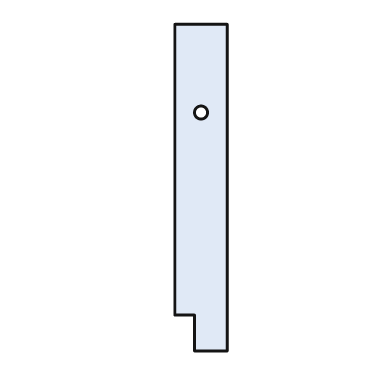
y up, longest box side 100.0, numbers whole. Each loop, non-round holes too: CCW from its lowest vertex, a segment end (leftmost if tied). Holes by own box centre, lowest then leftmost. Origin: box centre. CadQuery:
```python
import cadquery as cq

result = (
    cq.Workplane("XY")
    .moveTo(-2.0, -50.0)
    .lineTo(8.0, -50.0)
    .lineTo(8.0, 50.0)
    .lineTo(-8.0, 50.0)
    .lineTo(-8.0, -39.0)
    .lineTo(-2.0, -39.0)
    .close()
    .moveTo(0.0, 23.0)
    .circle(2.0)
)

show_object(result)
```